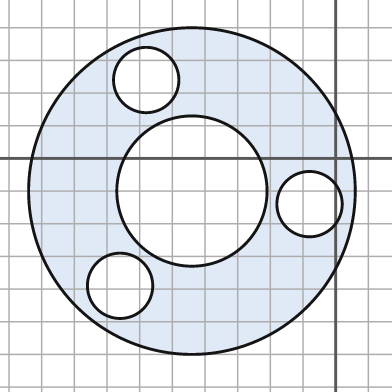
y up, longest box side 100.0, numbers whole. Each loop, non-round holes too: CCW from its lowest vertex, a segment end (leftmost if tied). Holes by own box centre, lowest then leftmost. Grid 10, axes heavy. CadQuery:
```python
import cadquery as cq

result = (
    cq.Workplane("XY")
    .moveTo(-44.0, -10.0)
    .circle(50.0)
    .moveTo(-66.0, -39.0)
    .circle(10.0)
    .moveTo(-8.0, -14.0)
    .circle(10.0)
    .moveTo(-44.0, -10.0)
    .circle(23.0)
    .moveTo(-58.0, 24.0)
    .circle(10.0)
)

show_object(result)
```